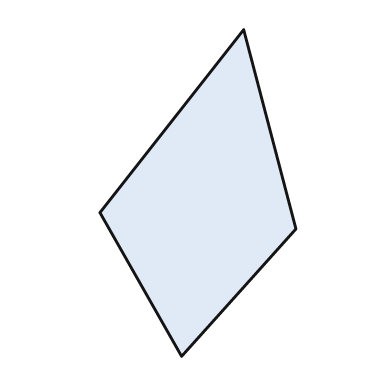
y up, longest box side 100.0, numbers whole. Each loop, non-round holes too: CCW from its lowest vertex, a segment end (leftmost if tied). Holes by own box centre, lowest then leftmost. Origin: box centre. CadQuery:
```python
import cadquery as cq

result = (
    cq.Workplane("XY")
    .moveTo(-5.0, -50.0)
    .lineTo(30.0, -11.0)
    .lineTo(14.0, 50.0)
    .lineTo(-30.0, -6.0)
    .close()
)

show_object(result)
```